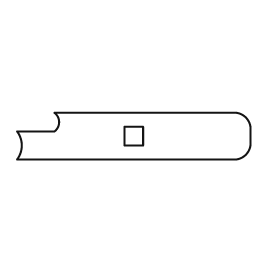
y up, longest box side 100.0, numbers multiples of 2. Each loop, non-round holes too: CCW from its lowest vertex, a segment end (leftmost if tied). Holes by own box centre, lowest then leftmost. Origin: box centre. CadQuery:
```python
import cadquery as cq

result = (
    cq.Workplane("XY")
    .moveTo(-50.0, -10.0)
    .lineTo(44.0, -10.0)
    .threePointArc((48.0, -8.0), (50.0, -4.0))
    .lineTo(50.0, 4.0)
    .threePointArc((48.0, 8.0), (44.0, 10.0))
    .lineTo(-34.0, 10.0)
    .threePointArc((-32.0, 6.0), (-34.0, 2.0))
    .lineTo(-50.0, 2.0)
    .threePointArc((-48.0, -4.0), (-50.0, -10.0))
    .close()
    .moveTo(-4.0, -4.0)
    .lineTo(4.0, -4.0)
    .lineTo(4.0, 4.0)
    .lineTo(-4.0, 4.0)
    .close()
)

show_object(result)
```